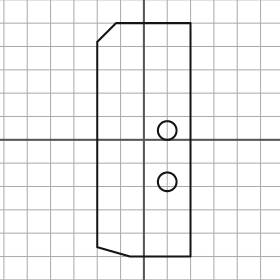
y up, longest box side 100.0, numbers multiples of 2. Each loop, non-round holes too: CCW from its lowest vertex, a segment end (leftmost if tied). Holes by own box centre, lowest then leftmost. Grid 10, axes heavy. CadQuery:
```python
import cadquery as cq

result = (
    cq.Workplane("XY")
    .moveTo(-6.0, -50.0)
    .lineTo(20.0, -50.0)
    .lineTo(20.0, 50.0)
    .lineTo(-12.0, 50.0)
    .lineTo(-20.0, 42.0)
    .lineTo(-20.0, -46.0)
    .close()
    .moveTo(10.0, -18.0)
    .circle(4.0)
    .moveTo(10.0, 4.0)
    .circle(4.0)
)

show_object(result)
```